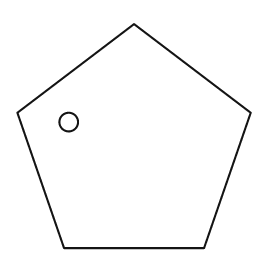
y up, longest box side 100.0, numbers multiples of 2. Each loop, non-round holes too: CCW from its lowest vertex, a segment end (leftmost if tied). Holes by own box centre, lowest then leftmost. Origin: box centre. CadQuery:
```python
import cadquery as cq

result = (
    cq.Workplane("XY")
    .moveTo(-30.0, -48.0)
    .lineTo(30.0, -48.0)
    .lineTo(50.0, 10.0)
    .lineTo(0.0, 48.0)
    .lineTo(-50.0, 10.0)
    .close()
    .moveTo(-28.0, 6.0)
    .circle(4.0)
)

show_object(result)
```